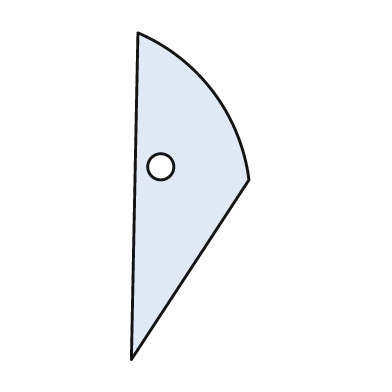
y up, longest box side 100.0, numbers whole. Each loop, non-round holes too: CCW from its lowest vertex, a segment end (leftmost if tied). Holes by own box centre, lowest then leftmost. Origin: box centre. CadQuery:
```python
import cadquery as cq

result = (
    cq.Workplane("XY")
    .moveTo(-18.0, -50.0)
    .lineTo(18.0, 5.0)
    .threePointArc((7.0, 32.0), (-16.0, 50.0))
    .close()
    .moveTo(-9.0, 9.0)
    .circle(4.0)
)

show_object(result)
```